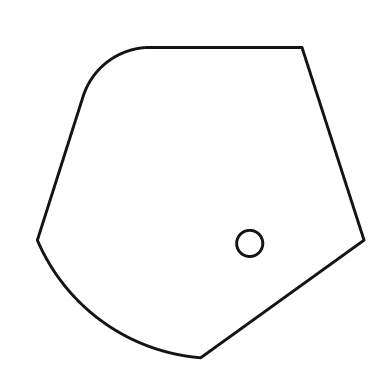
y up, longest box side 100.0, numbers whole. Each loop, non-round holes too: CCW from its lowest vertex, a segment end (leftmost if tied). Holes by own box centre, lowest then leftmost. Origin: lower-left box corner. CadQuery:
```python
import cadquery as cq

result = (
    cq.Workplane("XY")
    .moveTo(50.0, 0.0)
    .lineTo(100.0, 36.0)
    .lineTo(81.0, 95.0)
    .lineTo(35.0, 95.0)
    .threePointArc((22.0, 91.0), (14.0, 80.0))
    .lineTo(0.0, 36.0)
    .threePointArc((20.0, 11.0), (50.0, 0.0))
    .close()
    .moveTo(65.0, 35.0)
    .circle(4.0)
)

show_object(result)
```